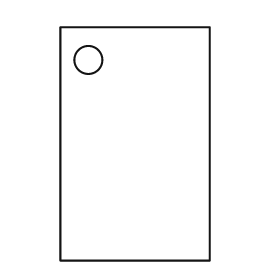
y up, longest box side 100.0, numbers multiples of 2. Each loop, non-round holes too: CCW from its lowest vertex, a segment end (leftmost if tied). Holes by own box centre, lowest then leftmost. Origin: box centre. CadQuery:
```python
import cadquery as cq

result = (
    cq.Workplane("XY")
    .moveTo(-32.0, -50.0)
    .lineTo(32.0, -50.0)
    .lineTo(32.0, 50.0)
    .lineTo(-32.0, 50.0)
    .close()
    .moveTo(-20.0, 36.0)
    .circle(6.0)
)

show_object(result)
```